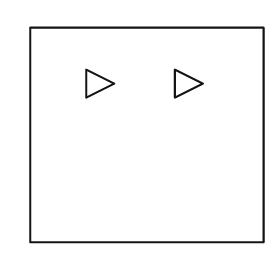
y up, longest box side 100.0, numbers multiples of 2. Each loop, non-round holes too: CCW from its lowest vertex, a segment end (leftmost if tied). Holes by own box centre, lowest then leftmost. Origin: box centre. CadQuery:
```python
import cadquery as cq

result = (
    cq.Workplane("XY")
    .moveTo(-50.0, -46.0)
    .lineTo(50.0, -46.0)
    .lineTo(50.0, 46.0)
    .lineTo(-50.0, 46.0)
    .close()
    .moveTo(-26.0, 16.0)
    .lineTo(-14.0, 22.0)
    .lineTo(-26.0, 28.0)
    .close()
    .moveTo(12.0, 16.0)
    .lineTo(24.0, 22.0)
    .lineTo(12.0, 28.0)
    .close()
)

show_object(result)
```